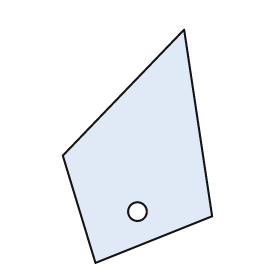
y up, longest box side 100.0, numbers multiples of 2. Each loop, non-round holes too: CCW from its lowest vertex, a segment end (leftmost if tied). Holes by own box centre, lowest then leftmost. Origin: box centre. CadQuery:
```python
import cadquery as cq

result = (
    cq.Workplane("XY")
    .moveTo(-18.0, -50.0)
    .lineTo(32.0, -30.0)
    .lineTo(20.0, 50.0)
    .lineTo(-32.0, -4.0)
    .close()
    .moveTo(0.0, -28.0)
    .circle(4.0)
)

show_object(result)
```